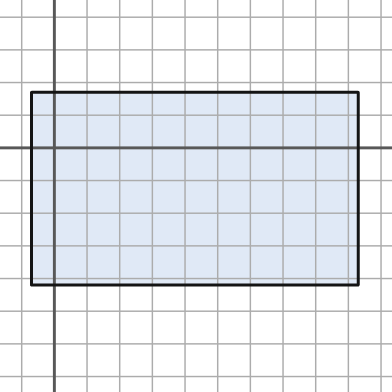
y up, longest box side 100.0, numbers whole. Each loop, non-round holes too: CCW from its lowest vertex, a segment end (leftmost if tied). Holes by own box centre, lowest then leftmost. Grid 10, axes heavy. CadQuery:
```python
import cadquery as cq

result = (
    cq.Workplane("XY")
    .moveTo(-7.0, -42.0)
    .lineTo(93.0, -42.0)
    .lineTo(93.0, 17.0)
    .lineTo(-7.0, 17.0)
    .close()
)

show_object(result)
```